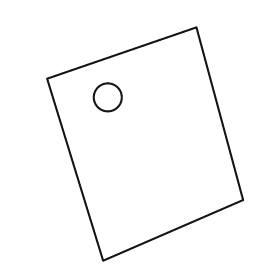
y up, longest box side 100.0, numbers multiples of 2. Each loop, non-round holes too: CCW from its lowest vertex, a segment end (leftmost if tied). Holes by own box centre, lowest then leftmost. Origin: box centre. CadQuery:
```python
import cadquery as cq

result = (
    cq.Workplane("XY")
    .moveTo(-18.0, -50.0)
    .lineTo(42.0, -24.0)
    .lineTo(22.0, 50.0)
    .lineTo(-42.0, 28.0)
    .close()
    .moveTo(-16.0, 20.0)
    .circle(6.0)
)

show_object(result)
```